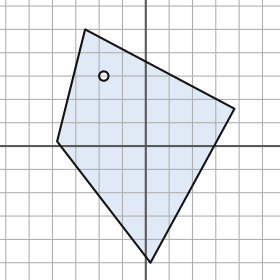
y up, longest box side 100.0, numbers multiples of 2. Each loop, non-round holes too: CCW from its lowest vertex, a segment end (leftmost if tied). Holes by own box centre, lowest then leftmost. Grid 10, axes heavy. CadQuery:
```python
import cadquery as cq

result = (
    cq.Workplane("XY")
    .moveTo(2.0, -50.0)
    .lineTo(38.0, 16.0)
    .lineTo(-26.0, 50.0)
    .lineTo(-38.0, 2.0)
    .close()
    .moveTo(-18.0, 30.0)
    .circle(2.0)
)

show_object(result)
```